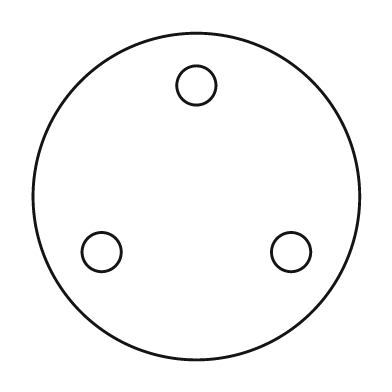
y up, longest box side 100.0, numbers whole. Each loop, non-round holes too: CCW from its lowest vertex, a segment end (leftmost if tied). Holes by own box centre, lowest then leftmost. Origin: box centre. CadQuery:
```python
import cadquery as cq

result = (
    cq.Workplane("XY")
    .moveTo(0.0, 0.0)
    .circle(50.0)
    .moveTo(-29.0, -17.0)
    .circle(6.0)
    .moveTo(29.0, -17.0)
    .circle(6.0)
    .moveTo(0.0, 34.0)
    .circle(6.0)
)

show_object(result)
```